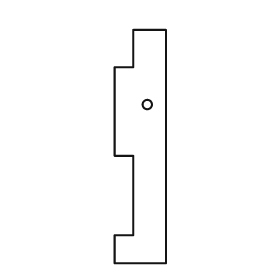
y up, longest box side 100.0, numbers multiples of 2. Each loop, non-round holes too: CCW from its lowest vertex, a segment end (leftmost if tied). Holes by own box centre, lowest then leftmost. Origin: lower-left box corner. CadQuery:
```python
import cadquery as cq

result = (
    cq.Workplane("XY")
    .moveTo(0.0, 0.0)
    .lineTo(22.0, 0.0)
    .lineTo(22.0, 100.0)
    .lineTo(8.0, 100.0)
    .lineTo(8.0, 84.0)
    .lineTo(0.0, 84.0)
    .lineTo(0.0, 46.0)
    .lineTo(8.0, 46.0)
    .lineTo(8.0, 12.0)
    .lineTo(0.0, 12.0)
    .close()
    .moveTo(14.0, 68.0)
    .circle(2.0)
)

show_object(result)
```